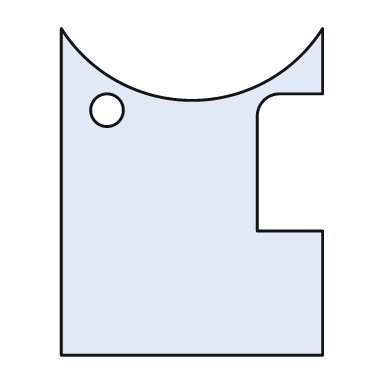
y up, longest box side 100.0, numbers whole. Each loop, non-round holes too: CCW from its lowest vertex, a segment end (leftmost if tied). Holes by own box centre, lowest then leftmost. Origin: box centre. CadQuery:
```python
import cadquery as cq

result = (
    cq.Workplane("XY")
    .moveTo(-40.0, -50.0)
    .lineTo(40.0, -50.0)
    .lineTo(40.0, -12.0)
    .lineTo(20.0, -12.0)
    .lineTo(20.0, 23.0)
    .threePointArc((22.0, 28.0), (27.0, 30.0))
    .lineTo(40.0, 30.0)
    .lineTo(40.0, 50.0)
    .threePointArc((0.0, 28.0), (-40.0, 50.0))
    .close()
    .moveTo(-26.0, 25.0)
    .circle(5.0)
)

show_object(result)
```